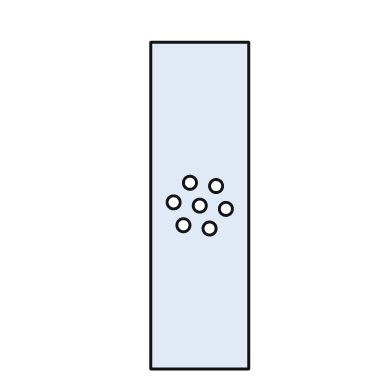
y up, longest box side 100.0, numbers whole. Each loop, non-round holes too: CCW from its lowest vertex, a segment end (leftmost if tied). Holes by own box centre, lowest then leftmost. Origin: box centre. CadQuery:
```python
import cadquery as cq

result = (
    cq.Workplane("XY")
    .moveTo(-15.0, -50.0)
    .lineTo(15.0, -50.0)
    .lineTo(15.0, 50.0)
    .lineTo(-15.0, 50.0)
    .close()
    .moveTo(3.0, -7.0)
    .circle(2.0)
    .moveTo(-5.0, -6.0)
    .circle(2.0)
    .moveTo(8.0, -1.0)
    .circle(2.0)
    .moveTo(0.0, 0.0)
    .circle(2.0)
    .moveTo(-8.0, 1.0)
    .circle(2.0)
    .moveTo(5.0, 6.0)
    .circle(2.0)
    .moveTo(-3.0, 7.0)
    .circle(2.0)
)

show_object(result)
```